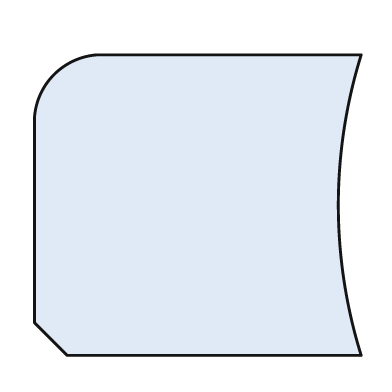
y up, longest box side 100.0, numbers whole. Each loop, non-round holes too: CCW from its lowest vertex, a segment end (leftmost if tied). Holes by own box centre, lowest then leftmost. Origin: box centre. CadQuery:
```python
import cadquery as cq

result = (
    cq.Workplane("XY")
    .moveTo(-40.0, -46.0)
    .lineTo(50.0, -46.0)
    .threePointArc((43.0, 0.0), (50.0, 46.0))
    .lineTo(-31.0, 46.0)
    .threePointArc((-44.0, 40.0), (-50.0, 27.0))
    .lineTo(-50.0, -36.0)
    .close()
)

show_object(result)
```